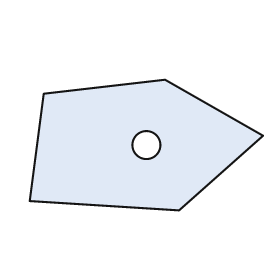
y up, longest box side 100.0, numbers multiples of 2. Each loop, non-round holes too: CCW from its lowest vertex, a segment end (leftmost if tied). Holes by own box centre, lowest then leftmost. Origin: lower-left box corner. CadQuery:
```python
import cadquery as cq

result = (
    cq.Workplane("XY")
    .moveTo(64.0, 0.0)
    .lineTo(100.0, 32.0)
    .lineTo(58.0, 56.0)
    .lineTo(6.0, 50.0)
    .lineTo(0.0, 4.0)
    .close()
    .moveTo(50.0, 28.0)
    .circle(6.0)
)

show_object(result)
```